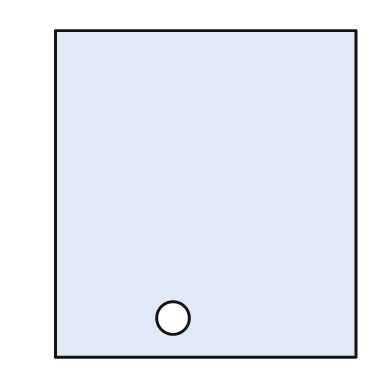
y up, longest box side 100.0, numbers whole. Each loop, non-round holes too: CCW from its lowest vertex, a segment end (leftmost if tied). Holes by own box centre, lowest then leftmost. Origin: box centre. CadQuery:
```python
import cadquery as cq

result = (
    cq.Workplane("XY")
    .moveTo(-46.0, -50.0)
    .lineTo(46.0, -50.0)
    .lineTo(46.0, 50.0)
    .lineTo(-46.0, 50.0)
    .close()
    .moveTo(-10.0, -38.0)
    .circle(5.0)
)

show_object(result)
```